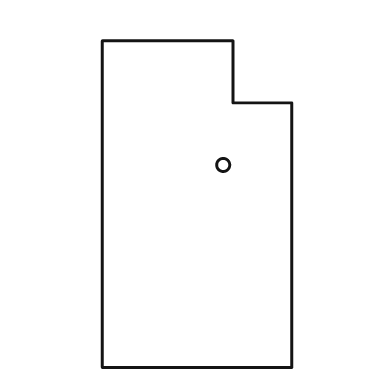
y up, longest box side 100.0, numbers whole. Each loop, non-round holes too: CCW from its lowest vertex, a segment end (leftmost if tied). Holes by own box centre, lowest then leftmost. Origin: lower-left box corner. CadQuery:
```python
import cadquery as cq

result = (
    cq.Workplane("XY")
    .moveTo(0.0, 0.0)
    .lineTo(58.0, 0.0)
    .lineTo(58.0, 81.0)
    .lineTo(40.0, 81.0)
    .lineTo(40.0, 100.0)
    .lineTo(0.0, 100.0)
    .close()
    .moveTo(37.0, 62.0)
    .circle(2.0)
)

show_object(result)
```